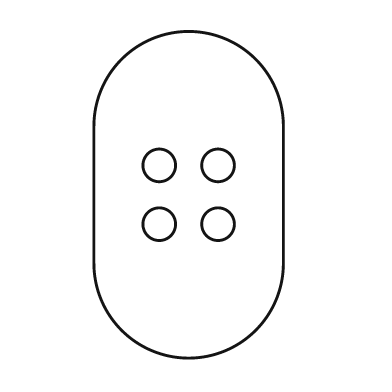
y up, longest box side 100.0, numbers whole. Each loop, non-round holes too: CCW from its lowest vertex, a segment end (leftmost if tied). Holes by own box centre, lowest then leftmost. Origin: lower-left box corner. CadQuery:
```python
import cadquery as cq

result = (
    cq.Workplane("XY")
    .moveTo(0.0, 29.0)
    .threePointArc((29.0, 0.0), (58.0, 29.0))
    .lineTo(58.0, 71.0)
    .threePointArc((29.0, 100.0), (0.0, 71.0))
    .close()
    .moveTo(20.0, 41.0)
    .circle(5.0)
    .moveTo(38.0, 41.0)
    .circle(5.0)
    .moveTo(20.0, 59.0)
    .circle(5.0)
    .moveTo(38.0, 59.0)
    .circle(5.0)
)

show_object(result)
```